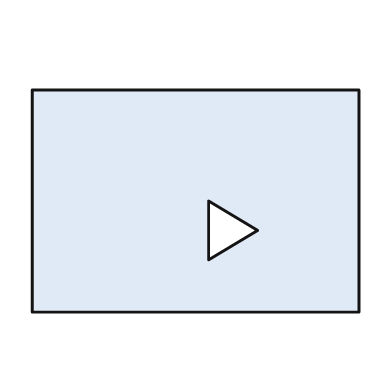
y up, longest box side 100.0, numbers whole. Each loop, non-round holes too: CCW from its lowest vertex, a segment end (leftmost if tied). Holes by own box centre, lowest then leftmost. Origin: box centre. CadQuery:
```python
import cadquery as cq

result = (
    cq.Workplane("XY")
    .moveTo(-50.0, -34.0)
    .lineTo(50.0, -34.0)
    .lineTo(50.0, 34.0)
    .lineTo(-50.0, 34.0)
    .close()
    .moveTo(4.0, -18.0)
    .lineTo(19.0, -9.0)
    .lineTo(4.0, 0.0)
    .close()
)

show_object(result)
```